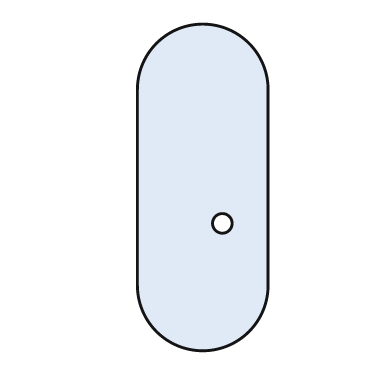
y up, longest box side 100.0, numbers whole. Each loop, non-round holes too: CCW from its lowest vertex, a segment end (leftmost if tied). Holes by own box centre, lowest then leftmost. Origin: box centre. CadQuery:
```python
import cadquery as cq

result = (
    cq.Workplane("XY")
    .moveTo(-20.0, -30.0)
    .threePointArc((0.0, -50.0), (20.0, -30.0))
    .lineTo(20.0, 30.0)
    .threePointArc((0.0, 50.0), (-20.0, 30.0))
    .close()
    .moveTo(6.0, -11.0)
    .circle(3.0)
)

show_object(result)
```